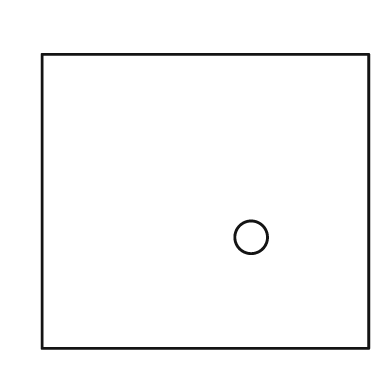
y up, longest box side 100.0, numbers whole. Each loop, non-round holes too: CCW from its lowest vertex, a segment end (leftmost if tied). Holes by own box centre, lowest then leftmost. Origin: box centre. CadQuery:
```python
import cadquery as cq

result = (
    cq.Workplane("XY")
    .moveTo(-50.0, -45.0)
    .lineTo(50.0, -45.0)
    .lineTo(50.0, 45.0)
    .lineTo(-50.0, 45.0)
    .close()
    .moveTo(14.0, -11.0)
    .circle(5.0)
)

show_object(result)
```